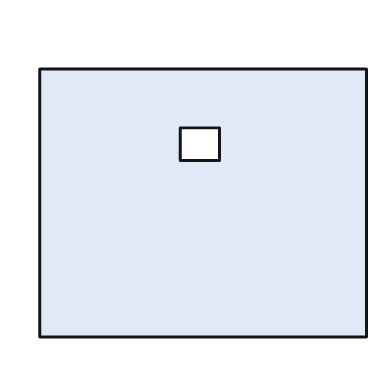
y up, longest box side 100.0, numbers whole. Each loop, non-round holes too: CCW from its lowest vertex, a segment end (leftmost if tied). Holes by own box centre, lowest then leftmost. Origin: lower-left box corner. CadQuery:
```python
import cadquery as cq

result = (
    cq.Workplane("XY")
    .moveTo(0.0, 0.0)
    .lineTo(100.0, 0.0)
    .lineTo(100.0, 82.0)
    .lineTo(0.0, 82.0)
    .close()
    .moveTo(43.0, 54.0)
    .lineTo(55.0, 54.0)
    .lineTo(55.0, 64.0)
    .lineTo(43.0, 64.0)
    .close()
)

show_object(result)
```